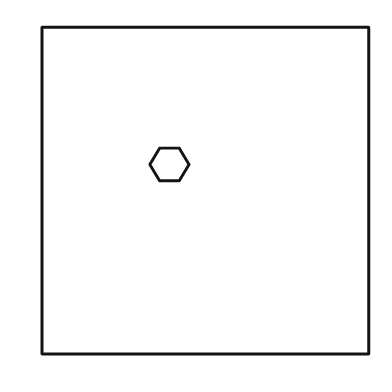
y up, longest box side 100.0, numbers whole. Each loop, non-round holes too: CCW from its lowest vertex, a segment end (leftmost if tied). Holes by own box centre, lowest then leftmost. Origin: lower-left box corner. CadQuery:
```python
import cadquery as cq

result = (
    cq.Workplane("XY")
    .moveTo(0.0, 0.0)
    .lineTo(100.0, 0.0)
    .lineTo(100.0, 100.0)
    .lineTo(0.0, 100.0)
    .close()
    .moveTo(36.0, 53.0)
    .lineTo(42.0, 53.0)
    .lineTo(45.0, 58.0)
    .lineTo(42.0, 63.0)
    .lineTo(36.0, 63.0)
    .lineTo(33.0, 58.0)
    .close()
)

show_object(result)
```